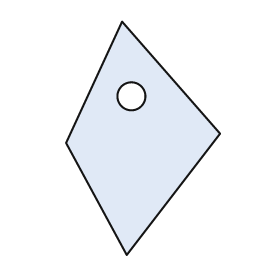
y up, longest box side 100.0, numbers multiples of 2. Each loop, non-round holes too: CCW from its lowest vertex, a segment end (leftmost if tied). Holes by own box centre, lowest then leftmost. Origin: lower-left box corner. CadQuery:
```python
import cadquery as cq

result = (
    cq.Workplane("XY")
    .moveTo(26.0, 0.0)
    .lineTo(66.0, 52.0)
    .lineTo(24.0, 100.0)
    .lineTo(0.0, 48.0)
    .close()
    .moveTo(28.0, 68.0)
    .circle(6.0)
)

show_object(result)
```